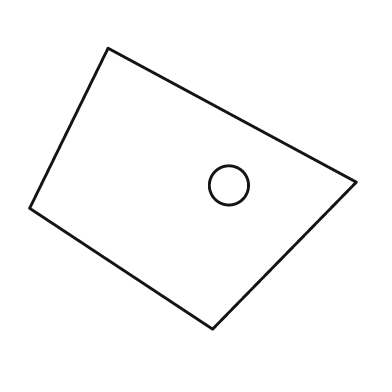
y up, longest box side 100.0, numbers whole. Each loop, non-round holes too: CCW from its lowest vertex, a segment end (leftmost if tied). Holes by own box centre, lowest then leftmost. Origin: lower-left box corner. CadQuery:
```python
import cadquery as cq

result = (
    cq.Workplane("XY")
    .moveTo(56.0, 0.0)
    .lineTo(100.0, 45.0)
    .lineTo(24.0, 86.0)
    .lineTo(0.0, 37.0)
    .close()
    .moveTo(61.0, 44.0)
    .circle(6.0)
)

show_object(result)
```